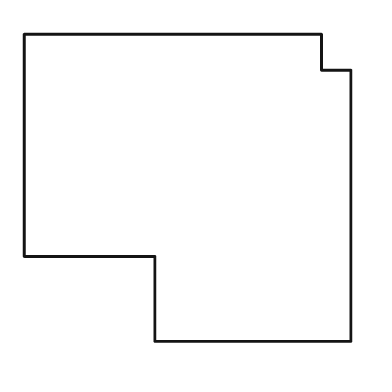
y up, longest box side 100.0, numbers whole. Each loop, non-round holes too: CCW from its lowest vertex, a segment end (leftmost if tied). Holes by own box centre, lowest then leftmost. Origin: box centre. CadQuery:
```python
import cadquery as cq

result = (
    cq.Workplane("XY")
    .moveTo(-10.0, -47.0)
    .lineTo(50.0, -47.0)
    .lineTo(50.0, 36.0)
    .lineTo(41.0, 36.0)
    .lineTo(41.0, 47.0)
    .lineTo(-50.0, 47.0)
    .lineTo(-50.0, -21.0)
    .lineTo(-10.0, -21.0)
    .close()
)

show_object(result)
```